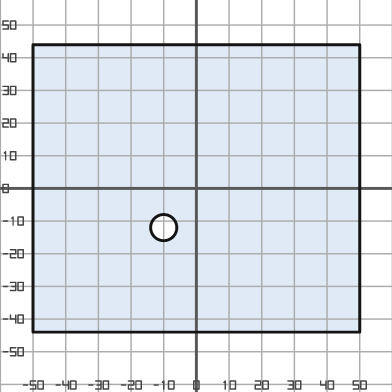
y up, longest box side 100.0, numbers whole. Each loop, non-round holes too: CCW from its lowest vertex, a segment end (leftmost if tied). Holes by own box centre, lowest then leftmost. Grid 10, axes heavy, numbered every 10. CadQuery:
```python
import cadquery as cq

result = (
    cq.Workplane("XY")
    .moveTo(-50.0, -44.0)
    .lineTo(50.0, -44.0)
    .lineTo(50.0, 44.0)
    .lineTo(-50.0, 44.0)
    .close()
    .moveTo(-10.0, -12.0)
    .circle(4.0)
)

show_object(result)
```